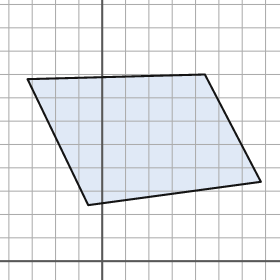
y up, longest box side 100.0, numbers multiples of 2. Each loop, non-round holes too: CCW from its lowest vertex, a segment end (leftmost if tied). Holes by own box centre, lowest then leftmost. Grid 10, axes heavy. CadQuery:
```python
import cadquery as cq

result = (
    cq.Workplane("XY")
    .moveTo(-6.0, 24.0)
    .lineTo(68.0, 34.0)
    .lineTo(44.0, 80.0)
    .lineTo(-32.0, 78.0)
    .close()
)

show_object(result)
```